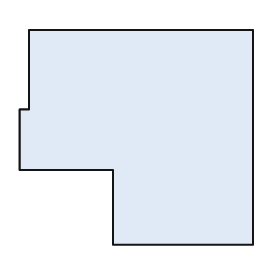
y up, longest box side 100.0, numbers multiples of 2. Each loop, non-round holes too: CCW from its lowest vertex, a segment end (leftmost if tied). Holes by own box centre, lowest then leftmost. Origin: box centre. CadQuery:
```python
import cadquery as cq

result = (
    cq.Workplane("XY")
    .moveTo(-10.0, -46.0)
    .lineTo(50.0, -46.0)
    .lineTo(50.0, 46.0)
    .lineTo(-46.0, 46.0)
    .lineTo(-46.0, 12.0)
    .lineTo(-50.0, 12.0)
    .lineTo(-50.0, -14.0)
    .lineTo(-10.0, -14.0)
    .close()
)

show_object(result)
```